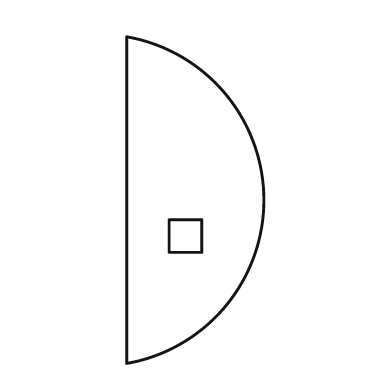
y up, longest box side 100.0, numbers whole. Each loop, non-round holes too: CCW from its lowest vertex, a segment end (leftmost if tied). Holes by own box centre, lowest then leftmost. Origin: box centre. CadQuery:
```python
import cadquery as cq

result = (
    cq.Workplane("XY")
    .moveTo(-21.0, -50.0)
    .threePointArc((21.0, 0.0), (-21.0, 50.0))
    .close()
    .moveTo(-8.0, -16.0)
    .lineTo(2.0, -16.0)
    .lineTo(2.0, -6.0)
    .lineTo(-8.0, -6.0)
    .close()
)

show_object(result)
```